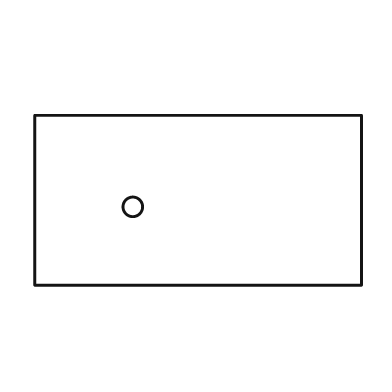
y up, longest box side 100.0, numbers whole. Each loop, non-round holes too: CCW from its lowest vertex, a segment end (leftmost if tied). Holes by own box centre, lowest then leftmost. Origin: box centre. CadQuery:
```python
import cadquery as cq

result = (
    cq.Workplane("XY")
    .moveTo(-50.0, -26.0)
    .lineTo(50.0, -26.0)
    .lineTo(50.0, 26.0)
    .lineTo(-50.0, 26.0)
    .close()
    .moveTo(-20.0, -2.0)
    .circle(3.0)
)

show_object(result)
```